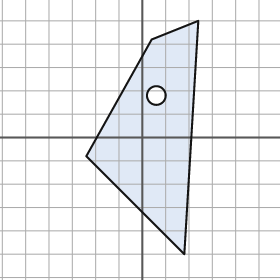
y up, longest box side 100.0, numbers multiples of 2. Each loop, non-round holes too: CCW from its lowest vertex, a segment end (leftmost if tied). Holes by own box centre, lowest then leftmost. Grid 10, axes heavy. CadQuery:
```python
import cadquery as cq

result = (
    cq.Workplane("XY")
    .moveTo(18.0, -50.0)
    .lineTo(24.0, 50.0)
    .lineTo(4.0, 42.0)
    .lineTo(-24.0, -8.0)
    .close()
    .moveTo(6.0, 18.0)
    .circle(4.0)
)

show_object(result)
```